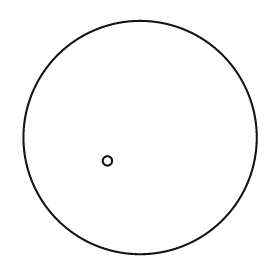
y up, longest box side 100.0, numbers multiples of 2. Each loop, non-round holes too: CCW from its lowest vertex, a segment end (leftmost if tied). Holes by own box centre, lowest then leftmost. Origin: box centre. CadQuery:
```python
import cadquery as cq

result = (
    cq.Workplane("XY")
    .moveTo(0.0, 0.0)
    .circle(50.0)
    .moveTo(-14.0, -10.0)
    .circle(2.0)
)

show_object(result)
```